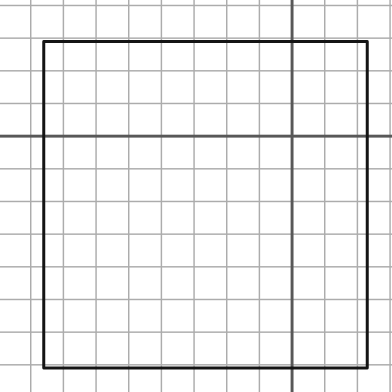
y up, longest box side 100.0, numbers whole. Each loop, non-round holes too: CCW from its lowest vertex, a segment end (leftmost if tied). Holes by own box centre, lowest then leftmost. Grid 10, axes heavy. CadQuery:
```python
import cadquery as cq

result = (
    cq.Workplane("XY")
    .moveTo(-76.0, -71.0)
    .lineTo(23.0, -71.0)
    .lineTo(23.0, 29.0)
    .lineTo(-76.0, 29.0)
    .close()
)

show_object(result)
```